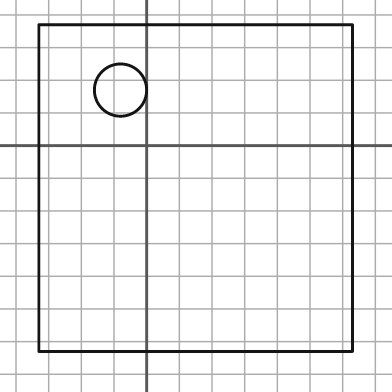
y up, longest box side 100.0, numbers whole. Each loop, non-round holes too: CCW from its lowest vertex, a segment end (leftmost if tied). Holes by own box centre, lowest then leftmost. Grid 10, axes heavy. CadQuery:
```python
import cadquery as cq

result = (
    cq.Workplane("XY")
    .moveTo(-33.0, -63.0)
    .lineTo(63.0, -63.0)
    .lineTo(63.0, 37.0)
    .lineTo(-33.0, 37.0)
    .close()
    .moveTo(-8.0, 17.0)
    .circle(8.0)
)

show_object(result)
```